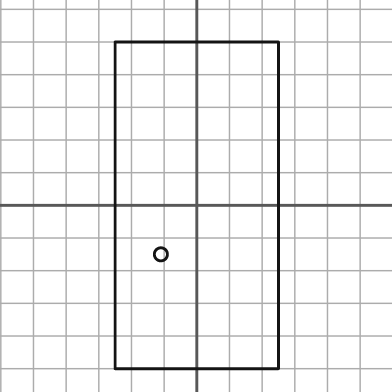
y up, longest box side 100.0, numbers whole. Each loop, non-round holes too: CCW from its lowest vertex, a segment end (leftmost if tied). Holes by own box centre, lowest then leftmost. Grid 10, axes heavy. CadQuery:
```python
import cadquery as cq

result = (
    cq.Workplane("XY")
    .moveTo(-25.0, -50.0)
    .lineTo(25.0, -50.0)
    .lineTo(25.0, 50.0)
    .lineTo(-25.0, 50.0)
    .close()
    .moveTo(-11.0, -15.0)
    .circle(2.0)
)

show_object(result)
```